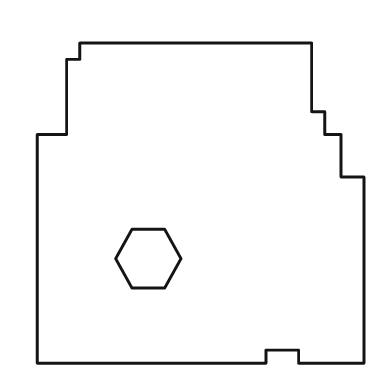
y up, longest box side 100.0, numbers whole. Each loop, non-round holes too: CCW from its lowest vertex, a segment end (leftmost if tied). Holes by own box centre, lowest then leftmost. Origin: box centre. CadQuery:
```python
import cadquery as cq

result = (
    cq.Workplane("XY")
    .moveTo(-50.0, -49.0)
    .lineTo(20.0, -49.0)
    .lineTo(20.0, -45.0)
    .lineTo(30.0, -45.0)
    .lineTo(30.0, -49.0)
    .lineTo(50.0, -49.0)
    .lineTo(50.0, 8.0)
    .lineTo(43.0, 8.0)
    .lineTo(43.0, 21.0)
    .lineTo(38.0, 21.0)
    .lineTo(38.0, 28.0)
    .lineTo(34.0, 28.0)
    .lineTo(34.0, 49.0)
    .lineTo(-37.0, 49.0)
    .lineTo(-37.0, 44.0)
    .lineTo(-41.0, 44.0)
    .lineTo(-41.0, 21.0)
    .lineTo(-50.0, 21.0)
    .close()
    .moveTo(-21.0, -26.0)
    .lineTo(-11.0, -26.0)
    .lineTo(-6.0, -17.0)
    .lineTo(-11.0, -8.0)
    .lineTo(-21.0, -8.0)
    .lineTo(-26.0, -17.0)
    .close()
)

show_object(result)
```